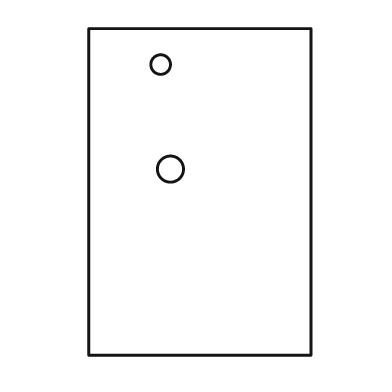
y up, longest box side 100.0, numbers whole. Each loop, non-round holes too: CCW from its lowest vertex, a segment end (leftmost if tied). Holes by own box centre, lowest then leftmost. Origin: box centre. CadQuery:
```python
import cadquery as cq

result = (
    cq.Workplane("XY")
    .moveTo(-34.0, -50.0)
    .lineTo(34.0, -50.0)
    .lineTo(34.0, 50.0)
    .lineTo(-34.0, 50.0)
    .close()
    .moveTo(-9.0, 7.0)
    .circle(4.0)
    .moveTo(-12.0, 39.0)
    .circle(3.0)
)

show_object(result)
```